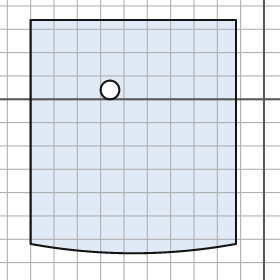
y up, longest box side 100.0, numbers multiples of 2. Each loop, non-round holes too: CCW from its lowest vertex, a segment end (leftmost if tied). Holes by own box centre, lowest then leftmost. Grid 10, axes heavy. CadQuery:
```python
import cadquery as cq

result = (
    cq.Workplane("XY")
    .moveTo(-100.0, -62.0)
    .threePointArc((-56.0, -66.0), (-12.0, -62.0))
    .lineTo(-12.0, 34.0)
    .lineTo(-100.0, 34.0)
    .close()
    .moveTo(-66.0, 4.0)
    .circle(4.0)
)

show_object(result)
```